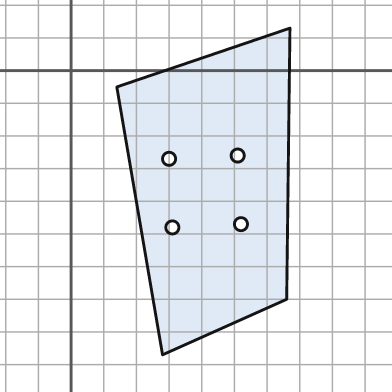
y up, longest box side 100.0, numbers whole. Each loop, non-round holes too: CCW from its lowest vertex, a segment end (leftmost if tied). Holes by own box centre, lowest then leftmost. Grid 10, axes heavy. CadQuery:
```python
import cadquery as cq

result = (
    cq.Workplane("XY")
    .moveTo(28.0, -87.0)
    .lineTo(66.0, -70.0)
    .lineTo(67.0, 13.0)
    .lineTo(14.0, -5.0)
    .close()
    .moveTo(31.0, -48.0)
    .circle(2.0)
    .moveTo(52.0, -47.0)
    .circle(2.0)
    .moveTo(30.0, -27.0)
    .circle(2.0)
    .moveTo(51.0, -26.0)
    .circle(2.0)
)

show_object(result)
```